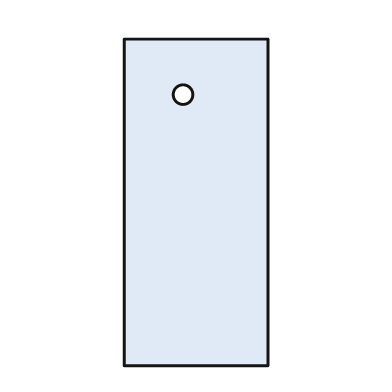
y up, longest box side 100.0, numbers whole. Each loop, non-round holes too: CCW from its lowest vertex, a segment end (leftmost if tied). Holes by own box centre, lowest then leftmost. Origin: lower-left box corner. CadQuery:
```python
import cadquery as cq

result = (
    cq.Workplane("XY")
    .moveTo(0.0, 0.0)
    .lineTo(44.0, 0.0)
    .lineTo(44.0, 100.0)
    .lineTo(0.0, 100.0)
    .close()
    .moveTo(18.0, 83.0)
    .circle(3.0)
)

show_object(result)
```